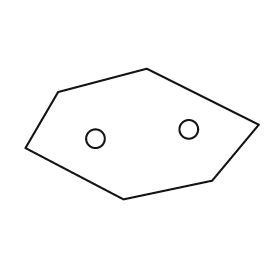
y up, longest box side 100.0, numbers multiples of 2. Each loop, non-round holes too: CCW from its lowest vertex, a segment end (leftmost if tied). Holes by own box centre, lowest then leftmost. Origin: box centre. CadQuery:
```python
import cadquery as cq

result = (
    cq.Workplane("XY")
    .moveTo(-8.0, -28.0)
    .lineTo(30.0, -20.0)
    .lineTo(50.0, 4.0)
    .lineTo(2.0, 28.0)
    .lineTo(-36.0, 18.0)
    .lineTo(-50.0, -6.0)
    .close()
    .moveTo(-20.0, -2.0)
    .circle(4.0)
    .moveTo(20.0, 2.0)
    .circle(4.0)
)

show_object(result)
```